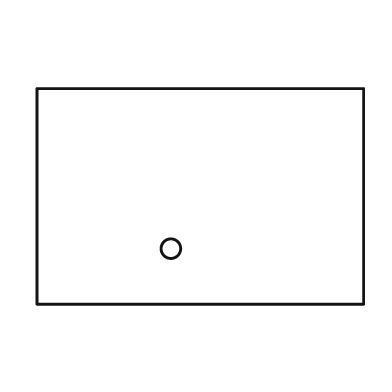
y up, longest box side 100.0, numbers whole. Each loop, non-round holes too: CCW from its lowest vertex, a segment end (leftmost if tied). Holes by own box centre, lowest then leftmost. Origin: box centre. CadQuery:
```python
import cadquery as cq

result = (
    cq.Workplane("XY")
    .moveTo(-50.0, -33.0)
    .lineTo(50.0, -33.0)
    .lineTo(50.0, 33.0)
    .lineTo(-50.0, 33.0)
    .close()
    .moveTo(-9.0, -16.0)
    .circle(3.0)
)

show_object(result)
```